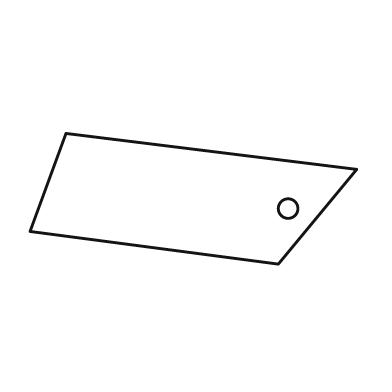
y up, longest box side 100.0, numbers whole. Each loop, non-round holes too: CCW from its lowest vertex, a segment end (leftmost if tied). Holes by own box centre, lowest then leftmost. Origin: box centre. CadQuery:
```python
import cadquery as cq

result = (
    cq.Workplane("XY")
    .moveTo(26.0, -20.0)
    .lineTo(50.0, 9.0)
    .lineTo(-39.0, 20.0)
    .lineTo(-50.0, -10.0)
    .close()
    .moveTo(29.0, -3.0)
    .circle(3.0)
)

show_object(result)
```